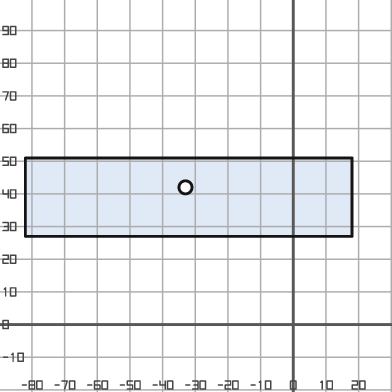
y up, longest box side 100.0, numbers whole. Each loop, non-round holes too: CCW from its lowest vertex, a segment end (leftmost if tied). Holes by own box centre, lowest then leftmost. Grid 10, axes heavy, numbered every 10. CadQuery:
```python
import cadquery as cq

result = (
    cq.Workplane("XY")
    .moveTo(-82.0, 27.0)
    .lineTo(18.0, 27.0)
    .lineTo(18.0, 51.0)
    .lineTo(-82.0, 51.0)
    .close()
    .moveTo(-33.0, 42.0)
    .circle(2.0)
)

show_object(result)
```